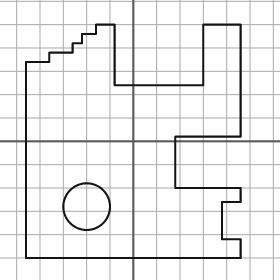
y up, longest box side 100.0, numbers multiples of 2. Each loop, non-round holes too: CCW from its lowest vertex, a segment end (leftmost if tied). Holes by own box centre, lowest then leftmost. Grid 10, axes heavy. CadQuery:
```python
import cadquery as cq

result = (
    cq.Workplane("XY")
    .moveTo(-46.0, -50.0)
    .lineTo(46.0, -50.0)
    .lineTo(46.0, -42.0)
    .lineTo(38.0, -42.0)
    .lineTo(38.0, -26.0)
    .lineTo(46.0, -26.0)
    .lineTo(46.0, -20.0)
    .lineTo(18.0, -20.0)
    .lineTo(18.0, 2.0)
    .lineTo(46.0, 2.0)
    .lineTo(46.0, 50.0)
    .lineTo(30.0, 50.0)
    .lineTo(30.0, 24.0)
    .lineTo(-8.0, 24.0)
    .lineTo(-8.0, 50.0)
    .lineTo(-16.0, 50.0)
    .lineTo(-16.0, 46.0)
    .lineTo(-22.0, 46.0)
    .lineTo(-22.0, 42.0)
    .lineTo(-26.0, 42.0)
    .lineTo(-26.0, 38.0)
    .lineTo(-36.0, 38.0)
    .lineTo(-36.0, 34.0)
    .lineTo(-46.0, 34.0)
    .close()
    .moveTo(-20.0, -28.0)
    .circle(10.0)
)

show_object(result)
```